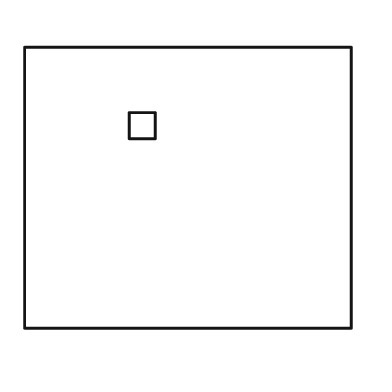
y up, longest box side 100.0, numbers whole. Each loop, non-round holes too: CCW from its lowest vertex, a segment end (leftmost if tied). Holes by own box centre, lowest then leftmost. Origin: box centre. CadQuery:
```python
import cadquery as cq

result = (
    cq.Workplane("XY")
    .moveTo(-50.0, -43.0)
    .lineTo(50.0, -43.0)
    .lineTo(50.0, 43.0)
    .lineTo(-50.0, 43.0)
    .close()
    .moveTo(-18.0, 15.0)
    .lineTo(-10.0, 15.0)
    .lineTo(-10.0, 23.0)
    .lineTo(-18.0, 23.0)
    .close()
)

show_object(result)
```